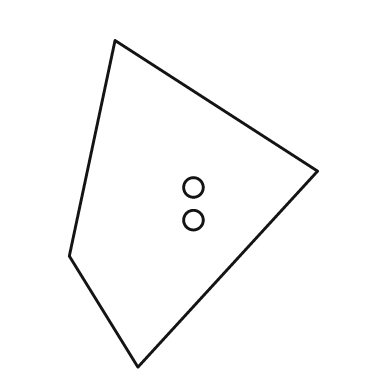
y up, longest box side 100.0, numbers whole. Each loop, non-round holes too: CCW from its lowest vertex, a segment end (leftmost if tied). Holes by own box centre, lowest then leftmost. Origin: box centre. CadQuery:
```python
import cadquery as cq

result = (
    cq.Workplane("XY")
    .moveTo(-17.0, -50.0)
    .lineTo(38.0, 10.0)
    .lineTo(-24.0, 50.0)
    .lineTo(-38.0, -16.0)
    .close()
    .moveTo(0.0, -5.0)
    .circle(3.0)
    .moveTo(0.0, 5.0)
    .circle(3.0)
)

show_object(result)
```